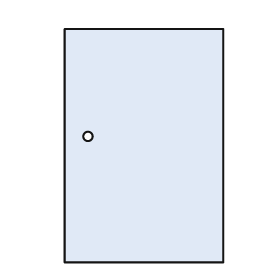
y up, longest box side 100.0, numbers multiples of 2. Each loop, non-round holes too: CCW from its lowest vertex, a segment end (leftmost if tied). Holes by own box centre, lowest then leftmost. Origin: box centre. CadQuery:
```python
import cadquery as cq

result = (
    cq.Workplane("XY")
    .moveTo(-34.0, -50.0)
    .lineTo(34.0, -50.0)
    .lineTo(34.0, 50.0)
    .lineTo(-34.0, 50.0)
    .close()
    .moveTo(-24.0, 4.0)
    .circle(2.0)
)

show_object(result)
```